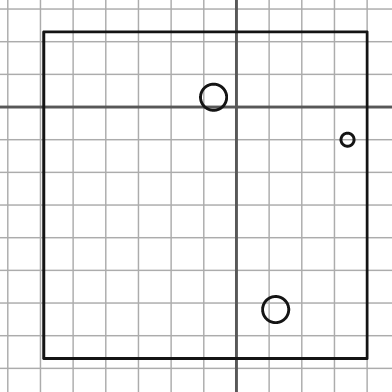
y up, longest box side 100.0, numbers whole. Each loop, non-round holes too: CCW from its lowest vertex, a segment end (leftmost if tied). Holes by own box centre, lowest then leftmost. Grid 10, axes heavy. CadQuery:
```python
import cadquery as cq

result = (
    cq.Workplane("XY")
    .moveTo(-59.0, -77.0)
    .lineTo(40.0, -77.0)
    .lineTo(40.0, 23.0)
    .lineTo(-59.0, 23.0)
    .close()
    .moveTo(12.0, -62.0)
    .circle(4.0)
    .moveTo(34.0, -10.0)
    .circle(2.0)
    .moveTo(-7.0, 3.0)
    .circle(4.0)
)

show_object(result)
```